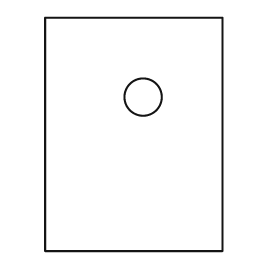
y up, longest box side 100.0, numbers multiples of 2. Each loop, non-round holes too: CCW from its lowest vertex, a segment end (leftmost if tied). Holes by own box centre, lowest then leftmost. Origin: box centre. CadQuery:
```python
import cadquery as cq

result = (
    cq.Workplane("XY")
    .moveTo(-38.0, -50.0)
    .lineTo(38.0, -50.0)
    .lineTo(38.0, 50.0)
    .lineTo(-38.0, 50.0)
    .close()
    .moveTo(4.0, 16.0)
    .circle(8.0)
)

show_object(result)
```